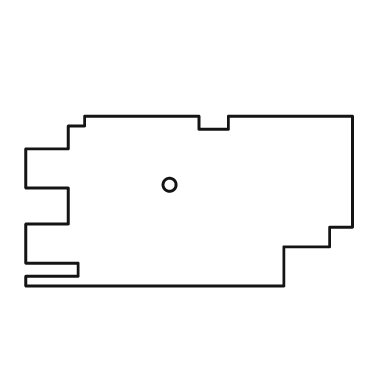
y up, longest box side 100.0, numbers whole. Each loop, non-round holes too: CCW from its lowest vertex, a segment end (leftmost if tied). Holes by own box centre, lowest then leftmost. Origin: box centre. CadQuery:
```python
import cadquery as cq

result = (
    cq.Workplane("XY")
    .moveTo(-50.0, -26.0)
    .lineTo(29.0, -26.0)
    .lineTo(29.0, -14.0)
    .lineTo(43.0, -14.0)
    .lineTo(43.0, -8.0)
    .lineTo(50.0, -8.0)
    .lineTo(50.0, 26.0)
    .lineTo(12.0, 26.0)
    .lineTo(12.0, 22.0)
    .lineTo(3.0, 22.0)
    .lineTo(3.0, 26.0)
    .lineTo(-32.0, 26.0)
    .lineTo(-32.0, 23.0)
    .lineTo(-37.0, 23.0)
    .lineTo(-37.0, 16.0)
    .lineTo(-50.0, 16.0)
    .lineTo(-50.0, 4.0)
    .lineTo(-37.0, 4.0)
    .lineTo(-37.0, -7.0)
    .lineTo(-50.0, -7.0)
    .lineTo(-50.0, -19.0)
    .lineTo(-34.0, -19.0)
    .lineTo(-34.0, -23.0)
    .lineTo(-50.0, -23.0)
    .close()
    .moveTo(-6.0, 5.0)
    .circle(2.0)
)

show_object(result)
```